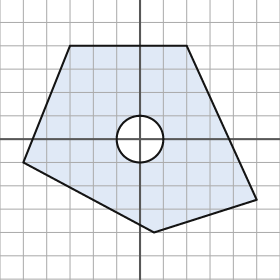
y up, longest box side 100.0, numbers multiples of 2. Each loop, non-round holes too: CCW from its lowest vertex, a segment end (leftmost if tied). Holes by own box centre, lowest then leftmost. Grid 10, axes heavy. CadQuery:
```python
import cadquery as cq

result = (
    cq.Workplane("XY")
    .moveTo(6.0, -40.0)
    .lineTo(50.0, -26.0)
    .lineTo(20.0, 40.0)
    .lineTo(-30.0, 40.0)
    .lineTo(-50.0, -10.0)
    .close()
    .moveTo(0.0, 0.0)
    .circle(10.0)
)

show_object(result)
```